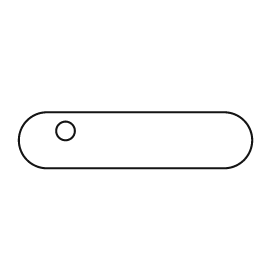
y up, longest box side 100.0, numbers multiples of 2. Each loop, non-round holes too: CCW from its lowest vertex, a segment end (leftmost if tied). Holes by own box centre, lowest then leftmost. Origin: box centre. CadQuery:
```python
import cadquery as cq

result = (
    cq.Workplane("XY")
    .moveTo(-38.0, -12.0)
    .lineTo(38.0, -12.0)
    .threePointArc((50.0, 0.0), (38.0, 12.0))
    .lineTo(-38.0, 12.0)
    .threePointArc((-50.0, 0.0), (-38.0, -12.0))
    .close()
    .moveTo(-30.0, 4.0)
    .circle(4.0)
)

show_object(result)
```